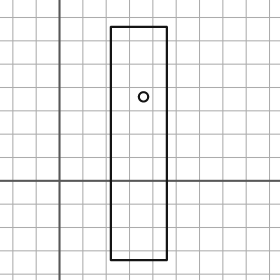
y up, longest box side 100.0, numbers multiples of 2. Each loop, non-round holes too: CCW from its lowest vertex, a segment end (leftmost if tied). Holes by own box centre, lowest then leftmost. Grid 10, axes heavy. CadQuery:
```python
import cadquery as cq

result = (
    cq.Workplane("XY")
    .moveTo(22.0, -34.0)
    .lineTo(46.0, -34.0)
    .lineTo(46.0, 66.0)
    .lineTo(22.0, 66.0)
    .close()
    .moveTo(36.0, 36.0)
    .circle(2.0)
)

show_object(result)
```